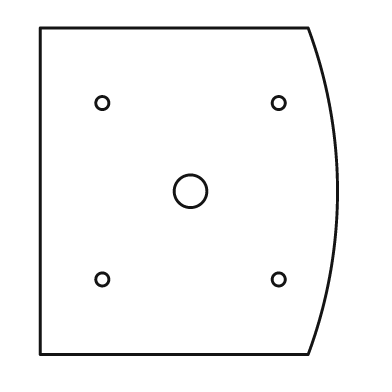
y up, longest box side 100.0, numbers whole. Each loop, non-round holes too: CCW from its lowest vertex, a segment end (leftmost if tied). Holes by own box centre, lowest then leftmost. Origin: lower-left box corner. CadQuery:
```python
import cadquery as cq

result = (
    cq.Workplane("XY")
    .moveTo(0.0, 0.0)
    .lineTo(82.0, 0.0)
    .threePointArc((91.0, 50.0), (82.0, 100.0))
    .lineTo(0.0, 100.0)
    .close()
    .moveTo(19.0, 23.0)
    .circle(2.0)
    .moveTo(73.0, 23.0)
    .circle(2.0)
    .moveTo(46.0, 50.0)
    .circle(5.0)
    .moveTo(19.0, 77.0)
    .circle(2.0)
    .moveTo(73.0, 77.0)
    .circle(2.0)
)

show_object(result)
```